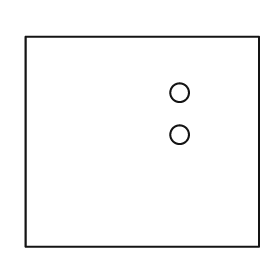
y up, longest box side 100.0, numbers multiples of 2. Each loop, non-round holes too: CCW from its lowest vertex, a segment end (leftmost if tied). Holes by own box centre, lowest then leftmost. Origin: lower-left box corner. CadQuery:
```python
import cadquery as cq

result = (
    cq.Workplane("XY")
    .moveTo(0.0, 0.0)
    .lineTo(100.0, 0.0)
    .lineTo(100.0, 90.0)
    .lineTo(0.0, 90.0)
    .close()
    .moveTo(66.0, 48.0)
    .circle(4.0)
    .moveTo(66.0, 66.0)
    .circle(4.0)
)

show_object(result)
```